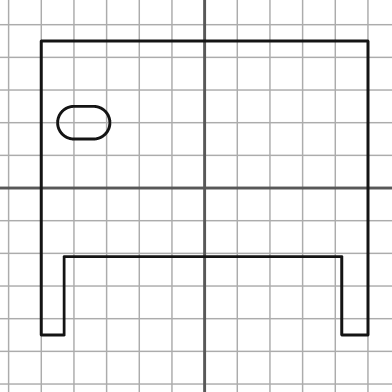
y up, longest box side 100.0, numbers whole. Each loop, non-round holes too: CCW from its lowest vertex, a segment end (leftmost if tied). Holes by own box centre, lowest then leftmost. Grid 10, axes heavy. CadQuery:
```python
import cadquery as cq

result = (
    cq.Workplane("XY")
    .moveTo(-50.0, -45.0)
    .lineTo(-43.0, -45.0)
    .lineTo(-43.0, -21.0)
    .lineTo(42.0, -21.0)
    .lineTo(42.0, -45.0)
    .lineTo(50.0, -45.0)
    .lineTo(50.0, 45.0)
    .lineTo(-50.0, 45.0)
    .close()
    .moveTo(-40.0, 15.0)
    .lineTo(-34.0, 15.0)
    .threePointArc((-29.0, 20.0), (-34.0, 25.0))
    .lineTo(-40.0, 25.0)
    .threePointArc((-45.0, 20.0), (-40.0, 15.0))
    .close()
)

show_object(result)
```